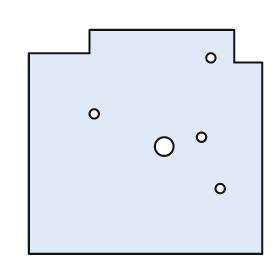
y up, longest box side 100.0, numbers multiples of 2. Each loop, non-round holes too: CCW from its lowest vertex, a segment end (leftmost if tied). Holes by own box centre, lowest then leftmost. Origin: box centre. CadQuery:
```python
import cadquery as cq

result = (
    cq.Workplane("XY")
    .moveTo(-50.0, -48.0)
    .lineTo(50.0, -48.0)
    .lineTo(50.0, 34.0)
    .lineTo(38.0, 34.0)
    .lineTo(38.0, 48.0)
    .lineTo(-24.0, 48.0)
    .lineTo(-24.0, 38.0)
    .lineTo(-50.0, 38.0)
    .close()
    .moveTo(32.0, -20.0)
    .circle(2.0)
    .moveTo(8.0, -2.0)
    .circle(4.0)
    .moveTo(24.0, 2.0)
    .circle(2.0)
    .moveTo(-22.0, 12.0)
    .circle(2.0)
    .moveTo(28.0, 36.0)
    .circle(2.0)
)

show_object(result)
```